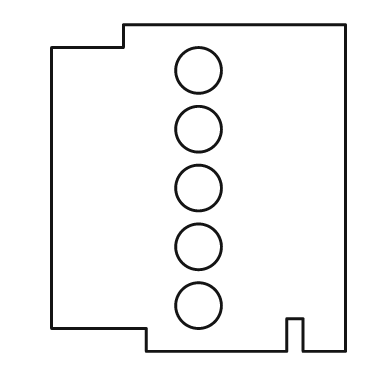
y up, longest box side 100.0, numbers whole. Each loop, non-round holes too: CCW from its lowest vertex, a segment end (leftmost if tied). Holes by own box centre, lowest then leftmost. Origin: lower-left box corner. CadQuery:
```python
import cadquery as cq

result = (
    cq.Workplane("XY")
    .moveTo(29.0, 0.0)
    .lineTo(72.0, 0.0)
    .lineTo(72.0, 10.0)
    .lineTo(77.0, 10.0)
    .lineTo(77.0, 0.0)
    .lineTo(90.0, 0.0)
    .lineTo(90.0, 100.0)
    .lineTo(22.0, 100.0)
    .lineTo(22.0, 93.0)
    .lineTo(0.0, 93.0)
    .lineTo(0.0, 7.0)
    .lineTo(29.0, 7.0)
    .close()
    .moveTo(45.0, 14.0)
    .circle(7.0)
    .moveTo(45.0, 32.0)
    .circle(7.0)
    .moveTo(45.0, 50.0)
    .circle(7.0)
    .moveTo(45.0, 68.0)
    .circle(7.0)
    .moveTo(45.0, 86.0)
    .circle(7.0)
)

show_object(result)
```